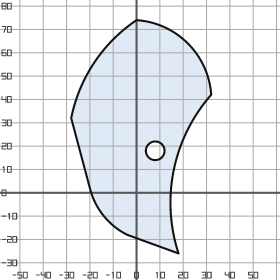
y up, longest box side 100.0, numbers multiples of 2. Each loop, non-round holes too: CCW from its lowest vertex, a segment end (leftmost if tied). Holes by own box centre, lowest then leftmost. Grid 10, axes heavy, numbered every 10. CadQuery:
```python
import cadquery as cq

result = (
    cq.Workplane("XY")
    .moveTo(18.0, -26.0)
    .threePointArc((16.0, 10.0), (32.0, 42.0))
    .threePointArc((22.0, 64.0), (0.0, 74.0))
    .threePointArc((-18.0, 56.0), (-28.0, 32.0))
    .lineTo(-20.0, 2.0)
    .threePointArc((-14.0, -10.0), (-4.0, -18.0))
    .close()
    .moveTo(8.0, 18.0)
    .circle(4.0)
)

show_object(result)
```